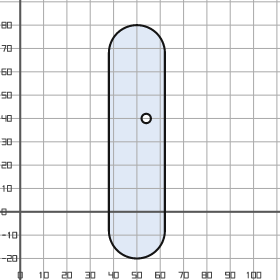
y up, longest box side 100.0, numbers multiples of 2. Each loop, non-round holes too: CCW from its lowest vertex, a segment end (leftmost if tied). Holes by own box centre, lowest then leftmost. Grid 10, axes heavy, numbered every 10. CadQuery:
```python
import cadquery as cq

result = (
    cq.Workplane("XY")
    .moveTo(38.0, -8.0)
    .threePointArc((50.0, -20.0), (62.0, -8.0))
    .lineTo(62.0, 68.0)
    .threePointArc((50.0, 80.0), (38.0, 68.0))
    .close()
    .moveTo(54.0, 40.0)
    .circle(2.0)
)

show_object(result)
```